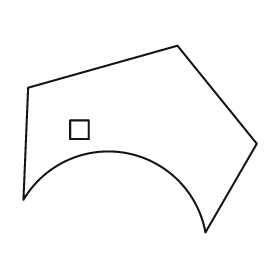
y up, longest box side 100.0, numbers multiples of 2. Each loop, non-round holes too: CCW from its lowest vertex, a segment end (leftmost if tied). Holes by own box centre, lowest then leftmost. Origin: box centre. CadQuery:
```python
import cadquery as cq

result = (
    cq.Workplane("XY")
    .moveTo(28.0, -40.0)
    .lineTo(50.0, -2.0)
    .lineTo(16.0, 40.0)
    .lineTo(-48.0, 22.0)
    .lineTo(-50.0, -26.0)
    .threePointArc((-6.0, -6.0), (28.0, -40.0))
    .close()
    .moveTo(-30.0, 0.0)
    .lineTo(-22.0, 0.0)
    .lineTo(-22.0, 8.0)
    .lineTo(-30.0, 8.0)
    .close()
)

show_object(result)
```